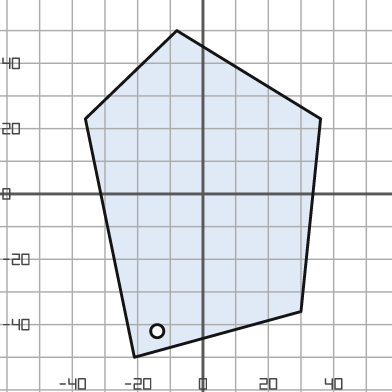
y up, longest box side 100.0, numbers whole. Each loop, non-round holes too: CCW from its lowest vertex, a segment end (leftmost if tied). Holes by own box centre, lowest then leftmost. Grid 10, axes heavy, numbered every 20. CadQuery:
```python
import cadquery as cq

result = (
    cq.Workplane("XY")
    .moveTo(-21.0, -50.0)
    .lineTo(30.0, -36.0)
    .lineTo(36.0, 23.0)
    .lineTo(-8.0, 50.0)
    .lineTo(-36.0, 23.0)
    .close()
    .moveTo(-14.0, -42.0)
    .circle(2.0)
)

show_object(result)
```